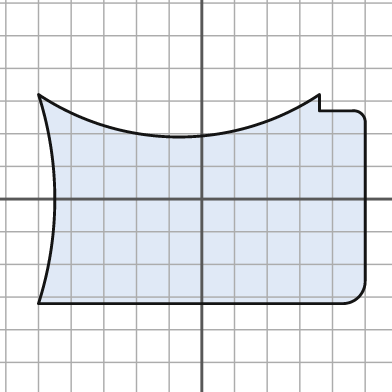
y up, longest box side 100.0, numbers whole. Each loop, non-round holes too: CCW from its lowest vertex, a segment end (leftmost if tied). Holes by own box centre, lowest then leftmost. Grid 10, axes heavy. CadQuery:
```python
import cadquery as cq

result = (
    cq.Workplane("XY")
    .moveTo(-50.0, -32.0)
    .lineTo(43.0, -32.0)
    .threePointArc((48.0, -30.0), (50.0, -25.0))
    .lineTo(50.0, 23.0)
    .threePointArc((49.0, 26.0), (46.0, 27.0))
    .lineTo(36.0, 27.0)
    .lineTo(36.0, 32.0)
    .threePointArc((-7.0, 19.0), (-50.0, 32.0))
    .threePointArc((-45.0, 0.0), (-50.0, -32.0))
    .close()
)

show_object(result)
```